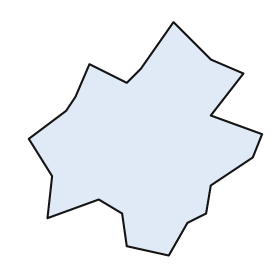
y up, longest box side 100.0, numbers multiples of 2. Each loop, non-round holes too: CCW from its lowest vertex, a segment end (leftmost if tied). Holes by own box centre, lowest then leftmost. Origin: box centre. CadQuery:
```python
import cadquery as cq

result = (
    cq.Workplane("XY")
    .moveTo(10.0, -50.0)
    .lineTo(18.0, -36.0)
    .lineTo(26.0, -32.0)
    .lineTo(28.0, -20.0)
    .lineTo(46.0, -8.0)
    .lineTo(50.0, 2.0)
    .lineTo(28.0, 10.0)
    .lineTo(42.0, 28.0)
    .lineTo(28.0, 34.0)
    .lineTo(12.0, 50.0)
    .lineTo(-2.0, 30.0)
    .lineTo(-8.0, 24.0)
    .lineTo(-24.0, 32.0)
    .lineTo(-30.0, 18.0)
    .lineTo(-34.0, 12.0)
    .lineTo(-50.0, 0.0)
    .lineTo(-40.0, -16.0)
    .lineTo(-42.0, -34.0)
    .lineTo(-20.0, -26.0)
    .lineTo(-10.0, -32.0)
    .lineTo(-8.0, -46.0)
    .close()
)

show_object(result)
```